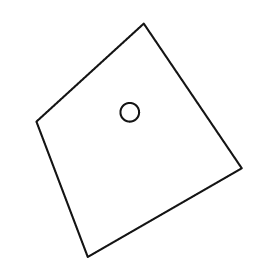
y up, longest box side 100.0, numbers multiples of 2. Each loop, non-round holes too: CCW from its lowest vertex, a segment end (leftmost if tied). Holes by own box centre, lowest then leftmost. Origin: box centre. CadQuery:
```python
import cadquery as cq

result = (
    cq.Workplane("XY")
    .moveTo(-22.0, -50.0)
    .lineTo(44.0, -12.0)
    .lineTo(2.0, 50.0)
    .lineTo(-44.0, 8.0)
    .close()
    .moveTo(-4.0, 12.0)
    .circle(4.0)
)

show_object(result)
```